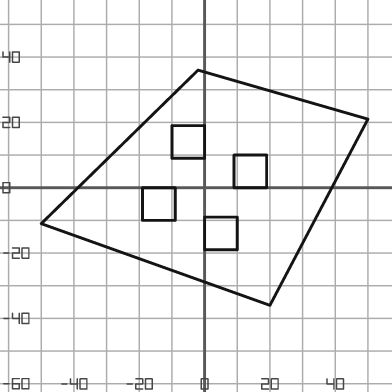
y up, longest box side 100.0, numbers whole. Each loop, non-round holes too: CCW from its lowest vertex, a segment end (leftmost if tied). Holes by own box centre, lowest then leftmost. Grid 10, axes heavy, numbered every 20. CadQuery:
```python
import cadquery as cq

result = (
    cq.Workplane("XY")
    .moveTo(20.0, -36.0)
    .lineTo(50.0, 21.0)
    .lineTo(-2.0, 36.0)
    .lineTo(-50.0, -11.0)
    .close()
    .moveTo(0.0, -19.0)
    .lineTo(10.0, -19.0)
    .lineTo(10.0, -9.0)
    .lineTo(0.0, -9.0)
    .close()
    .moveTo(-19.0, -10.0)
    .lineTo(-9.0, -10.0)
    .lineTo(-9.0, 0.0)
    .lineTo(-19.0, 0.0)
    .close()
    .moveTo(9.0, 0.0)
    .lineTo(19.0, 0.0)
    .lineTo(19.0, 10.0)
    .lineTo(9.0, 10.0)
    .close()
    .moveTo(-10.0, 9.0)
    .lineTo(0.0, 9.0)
    .lineTo(0.0, 19.0)
    .lineTo(-10.0, 19.0)
    .close()
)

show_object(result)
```